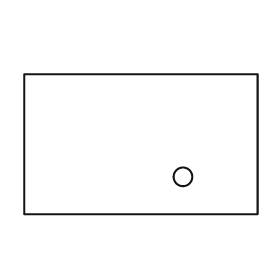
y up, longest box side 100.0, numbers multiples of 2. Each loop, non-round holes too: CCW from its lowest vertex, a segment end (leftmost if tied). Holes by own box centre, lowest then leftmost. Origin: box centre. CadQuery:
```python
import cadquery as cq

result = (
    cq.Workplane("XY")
    .moveTo(-50.0, -30.0)
    .lineTo(50.0, -30.0)
    .lineTo(50.0, 30.0)
    .lineTo(-50.0, 30.0)
    .close()
    .moveTo(18.0, -14.0)
    .circle(4.0)
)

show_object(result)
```